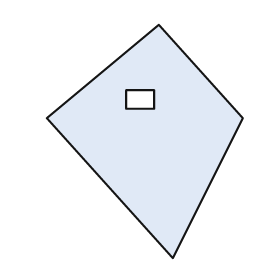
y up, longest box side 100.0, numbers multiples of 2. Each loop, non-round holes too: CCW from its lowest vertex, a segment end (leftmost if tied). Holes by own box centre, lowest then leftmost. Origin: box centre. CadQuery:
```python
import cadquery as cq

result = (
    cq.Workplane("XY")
    .moveTo(12.0, -50.0)
    .lineTo(42.0, 10.0)
    .lineTo(6.0, 50.0)
    .lineTo(-42.0, 10.0)
    .close()
    .moveTo(-8.0, 14.0)
    .lineTo(4.0, 14.0)
    .lineTo(4.0, 22.0)
    .lineTo(-8.0, 22.0)
    .close()
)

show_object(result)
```